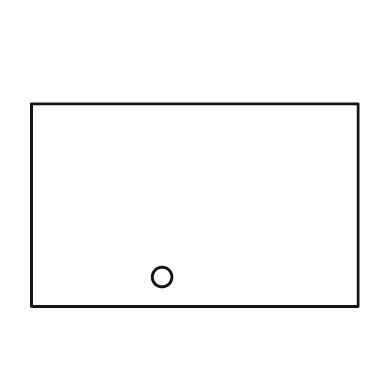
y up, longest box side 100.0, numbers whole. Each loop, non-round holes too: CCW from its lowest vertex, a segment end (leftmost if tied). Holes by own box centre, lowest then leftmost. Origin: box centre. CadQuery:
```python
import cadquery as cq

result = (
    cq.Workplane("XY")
    .moveTo(-50.0, -31.0)
    .lineTo(50.0, -31.0)
    .lineTo(50.0, 31.0)
    .lineTo(-50.0, 31.0)
    .close()
    .moveTo(-10.0, -22.0)
    .circle(3.0)
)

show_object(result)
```